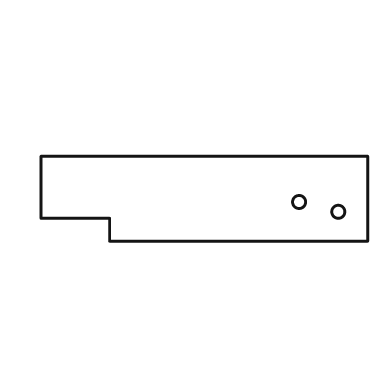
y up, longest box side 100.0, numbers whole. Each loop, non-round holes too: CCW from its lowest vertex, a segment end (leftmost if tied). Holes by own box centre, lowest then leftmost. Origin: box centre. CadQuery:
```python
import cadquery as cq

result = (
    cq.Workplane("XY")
    .moveTo(-29.0, -13.0)
    .lineTo(50.0, -13.0)
    .lineTo(50.0, 13.0)
    .lineTo(-50.0, 13.0)
    .lineTo(-50.0, -6.0)
    .lineTo(-29.0, -6.0)
    .close()
    .moveTo(41.0, -4.0)
    .circle(2.0)
    .moveTo(29.0, -1.0)
    .circle(2.0)
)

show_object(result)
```